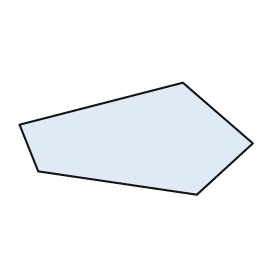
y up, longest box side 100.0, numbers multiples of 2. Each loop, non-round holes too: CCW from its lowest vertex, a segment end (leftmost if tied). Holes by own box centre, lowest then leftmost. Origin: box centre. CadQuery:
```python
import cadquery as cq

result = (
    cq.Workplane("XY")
    .moveTo(26.0, -24.0)
    .lineTo(50.0, -2.0)
    .lineTo(20.0, 24.0)
    .lineTo(-50.0, 6.0)
    .lineTo(-42.0, -14.0)
    .close()
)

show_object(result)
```